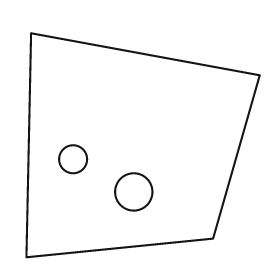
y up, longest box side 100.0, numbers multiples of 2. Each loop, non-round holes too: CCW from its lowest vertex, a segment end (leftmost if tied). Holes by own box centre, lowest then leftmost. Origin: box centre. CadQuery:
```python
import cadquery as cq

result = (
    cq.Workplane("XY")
    .moveTo(-50.0, -48.0)
    .lineTo(30.0, -40.0)
    .lineTo(50.0, 30.0)
    .lineTo(-48.0, 48.0)
    .close()
    .moveTo(-4.0, -20.0)
    .circle(8.0)
    .moveTo(-30.0, -6.0)
    .circle(6.0)
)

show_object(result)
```